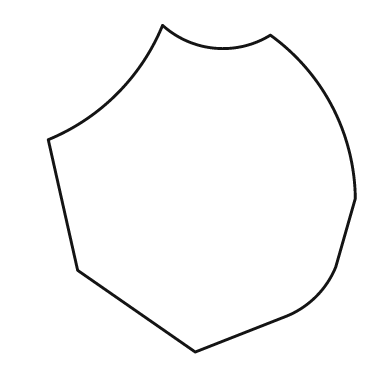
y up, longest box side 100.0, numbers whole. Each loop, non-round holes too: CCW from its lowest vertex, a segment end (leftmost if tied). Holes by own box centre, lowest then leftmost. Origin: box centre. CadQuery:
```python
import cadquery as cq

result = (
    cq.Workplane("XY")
    .moveTo(-2.0, -50.0)
    .lineTo(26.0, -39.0)
    .threePointArc((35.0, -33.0), (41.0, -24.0))
    .lineTo(47.0, -3.0)
    .threePointArc((40.0, 25.0), (21.0, 47.0))
    .threePointArc((4.0, 43.0), (-12.0, 50.0))
    .threePointArc((-26.0, 29.0), (-47.0, 15.0))
    .lineTo(-38.0, -25.0)
    .close()
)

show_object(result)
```